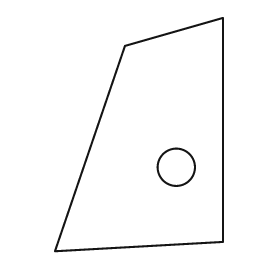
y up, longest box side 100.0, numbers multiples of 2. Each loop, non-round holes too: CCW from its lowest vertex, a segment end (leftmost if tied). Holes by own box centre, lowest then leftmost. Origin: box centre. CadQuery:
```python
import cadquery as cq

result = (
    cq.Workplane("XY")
    .moveTo(-36.0, -50.0)
    .lineTo(36.0, -46.0)
    .lineTo(36.0, 50.0)
    .lineTo(-6.0, 38.0)
    .close()
    .moveTo(16.0, -14.0)
    .circle(8.0)
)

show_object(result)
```